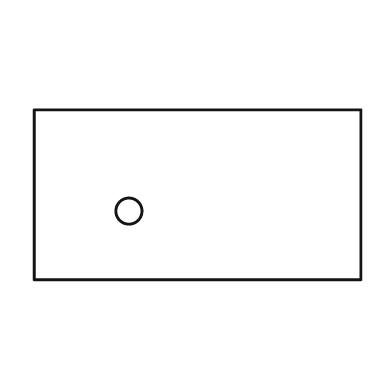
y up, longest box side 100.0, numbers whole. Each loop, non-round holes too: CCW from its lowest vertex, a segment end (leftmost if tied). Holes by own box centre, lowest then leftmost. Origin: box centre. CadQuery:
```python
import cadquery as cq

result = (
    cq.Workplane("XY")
    .moveTo(-50.0, -26.0)
    .lineTo(50.0, -26.0)
    .lineTo(50.0, 26.0)
    .lineTo(-50.0, 26.0)
    .close()
    .moveTo(-21.0, -5.0)
    .circle(4.0)
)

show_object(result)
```